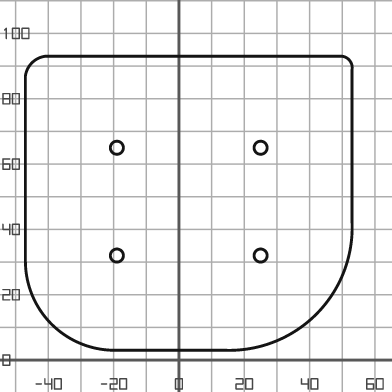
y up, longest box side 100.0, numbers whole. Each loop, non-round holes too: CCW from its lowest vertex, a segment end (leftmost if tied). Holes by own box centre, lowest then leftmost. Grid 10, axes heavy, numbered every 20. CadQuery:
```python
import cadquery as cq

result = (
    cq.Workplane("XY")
    .moveTo(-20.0, 3.0)
    .lineTo(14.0, 3.0)
    .threePointArc((42.0, 14.0), (53.0, 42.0))
    .lineTo(53.0, 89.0)
    .threePointArc((52.0, 92.0), (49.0, 93.0))
    .lineTo(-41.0, 93.0)
    .threePointArc((-45.0, 91.0), (-47.0, 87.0))
    .lineTo(-47.0, 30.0)
    .threePointArc((-39.0, 11.0), (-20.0, 3.0))
    .close()
    .moveTo(-19.0, 32.0)
    .circle(2.0)
    .moveTo(25.0, 32.0)
    .circle(2.0)
    .moveTo(-19.0, 65.0)
    .circle(2.0)
    .moveTo(25.0, 65.0)
    .circle(2.0)
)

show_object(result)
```